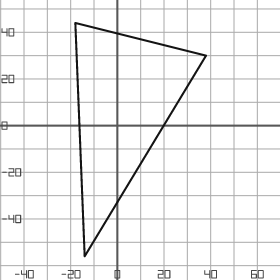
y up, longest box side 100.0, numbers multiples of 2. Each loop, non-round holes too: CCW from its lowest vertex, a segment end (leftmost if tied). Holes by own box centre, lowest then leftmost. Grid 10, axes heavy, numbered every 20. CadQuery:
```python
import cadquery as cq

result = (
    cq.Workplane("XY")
    .moveTo(-14.0, -56.0)
    .lineTo(38.0, 30.0)
    .lineTo(-18.0, 44.0)
    .close()
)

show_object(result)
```